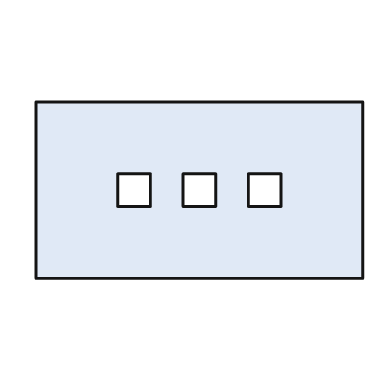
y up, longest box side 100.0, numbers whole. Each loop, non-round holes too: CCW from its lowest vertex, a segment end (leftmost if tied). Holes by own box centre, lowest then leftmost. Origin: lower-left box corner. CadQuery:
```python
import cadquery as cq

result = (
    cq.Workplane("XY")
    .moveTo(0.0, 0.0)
    .lineTo(100.0, 0.0)
    .lineTo(100.0, 54.0)
    .lineTo(0.0, 54.0)
    .close()
    .moveTo(25.0, 22.0)
    .lineTo(35.0, 22.0)
    .lineTo(35.0, 32.0)
    .lineTo(25.0, 32.0)
    .close()
    .moveTo(45.0, 22.0)
    .lineTo(55.0, 22.0)
    .lineTo(55.0, 32.0)
    .lineTo(45.0, 32.0)
    .close()
    .moveTo(65.0, 22.0)
    .lineTo(75.0, 22.0)
    .lineTo(75.0, 32.0)
    .lineTo(65.0, 32.0)
    .close()
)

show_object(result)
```